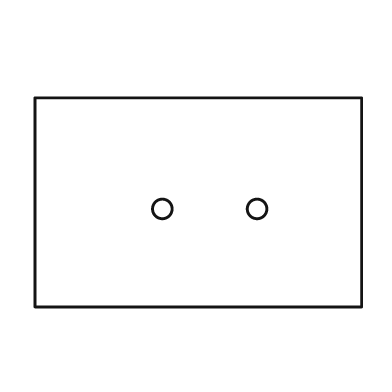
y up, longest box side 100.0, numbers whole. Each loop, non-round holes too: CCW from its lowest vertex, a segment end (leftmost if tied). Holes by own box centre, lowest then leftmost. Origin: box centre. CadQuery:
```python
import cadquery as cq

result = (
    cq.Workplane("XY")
    .moveTo(-50.0, -32.0)
    .lineTo(50.0, -32.0)
    .lineTo(50.0, 32.0)
    .lineTo(-50.0, 32.0)
    .close()
    .moveTo(-11.0, -2.0)
    .circle(3.0)
    .moveTo(18.0, -2.0)
    .circle(3.0)
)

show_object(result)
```